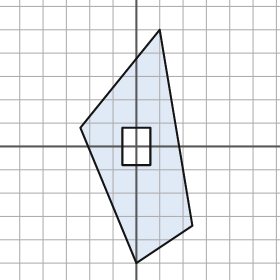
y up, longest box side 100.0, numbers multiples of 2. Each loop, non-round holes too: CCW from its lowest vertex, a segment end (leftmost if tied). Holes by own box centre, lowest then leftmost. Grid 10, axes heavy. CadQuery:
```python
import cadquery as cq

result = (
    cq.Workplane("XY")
    .moveTo(0.0, -50.0)
    .lineTo(24.0, -34.0)
    .lineTo(10.0, 50.0)
    .lineTo(-24.0, 8.0)
    .close()
    .moveTo(-6.0, -8.0)
    .lineTo(6.0, -8.0)
    .lineTo(6.0, 8.0)
    .lineTo(-6.0, 8.0)
    .close()
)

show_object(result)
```